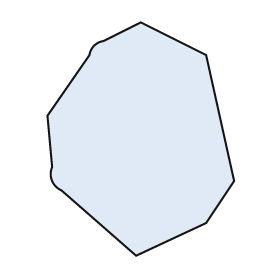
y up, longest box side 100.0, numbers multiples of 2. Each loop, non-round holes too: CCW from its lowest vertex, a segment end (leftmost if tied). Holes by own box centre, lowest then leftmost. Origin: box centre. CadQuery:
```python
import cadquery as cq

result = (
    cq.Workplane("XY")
    .moveTo(-2.0, -50.0)
    .lineTo(28.0, -36.0)
    .lineTo(40.0, -18.0)
    .lineTo(28.0, 36.0)
    .lineTo(0.0, 50.0)
    .lineTo(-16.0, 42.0)
    .threePointArc((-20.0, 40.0), (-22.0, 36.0))
    .lineTo(-40.0, 10.0)
    .lineTo(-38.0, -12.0)
    .threePointArc((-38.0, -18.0), (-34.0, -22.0))
    .close()
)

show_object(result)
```